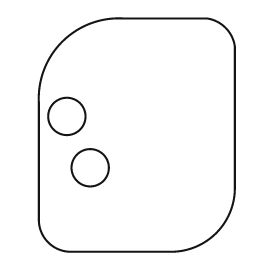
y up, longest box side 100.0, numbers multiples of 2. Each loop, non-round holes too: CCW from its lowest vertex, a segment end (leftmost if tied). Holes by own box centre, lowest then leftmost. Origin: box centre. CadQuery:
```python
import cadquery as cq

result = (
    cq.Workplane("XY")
    .moveTo(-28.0, -50.0)
    .lineTo(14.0, -50.0)
    .threePointArc((34.0, -42.0), (42.0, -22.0))
    .lineTo(42.0, 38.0)
    .threePointArc((38.0, 46.0), (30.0, 50.0))
    .lineTo(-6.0, 50.0)
    .threePointArc((-32.0, 40.0), (-42.0, 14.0))
    .lineTo(-42.0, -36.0)
    .threePointArc((-38.0, -46.0), (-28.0, -50.0))
    .close()
    .moveTo(-20.0, -14.0)
    .circle(8.0)
    .moveTo(-30.0, 8.0)
    .circle(8.0)
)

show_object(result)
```